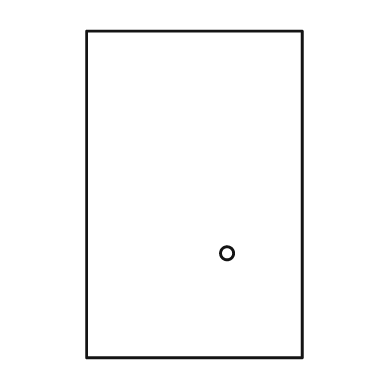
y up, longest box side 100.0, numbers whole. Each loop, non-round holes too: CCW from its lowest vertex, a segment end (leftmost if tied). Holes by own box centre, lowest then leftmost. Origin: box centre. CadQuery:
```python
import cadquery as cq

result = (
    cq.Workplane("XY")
    .moveTo(-33.0, -50.0)
    .lineTo(33.0, -50.0)
    .lineTo(33.0, 50.0)
    .lineTo(-33.0, 50.0)
    .close()
    .moveTo(10.0, -18.0)
    .circle(2.0)
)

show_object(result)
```